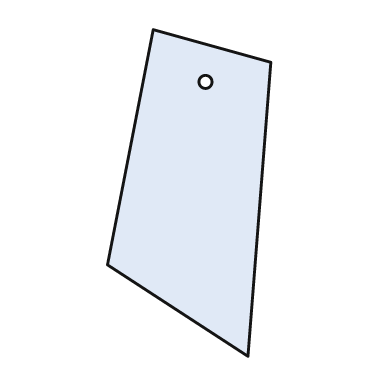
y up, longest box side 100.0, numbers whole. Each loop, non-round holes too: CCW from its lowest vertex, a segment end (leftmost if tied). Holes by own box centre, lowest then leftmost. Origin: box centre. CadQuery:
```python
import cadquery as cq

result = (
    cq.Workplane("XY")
    .moveTo(18.0, -50.0)
    .lineTo(25.0, 40.0)
    .lineTo(-11.0, 50.0)
    .lineTo(-25.0, -22.0)
    .close()
    .moveTo(5.0, 34.0)
    .circle(2.0)
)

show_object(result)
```